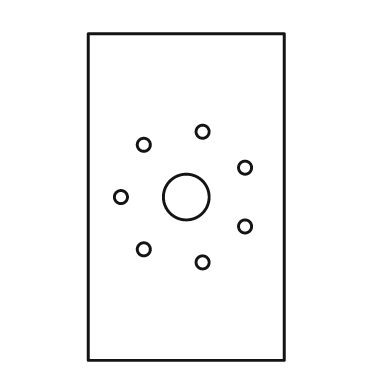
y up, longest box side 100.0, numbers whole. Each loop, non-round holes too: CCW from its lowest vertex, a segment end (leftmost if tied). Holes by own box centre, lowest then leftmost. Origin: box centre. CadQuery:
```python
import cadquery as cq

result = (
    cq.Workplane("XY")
    .moveTo(-30.0, -50.0)
    .lineTo(30.0, -50.0)
    .lineTo(30.0, 50.0)
    .lineTo(-30.0, 50.0)
    .close()
    .moveTo(5.0, -20.0)
    .circle(2.0)
    .moveTo(-13.0, -16.0)
    .circle(2.0)
    .moveTo(18.0, -9.0)
    .circle(2.0)
    .moveTo(-20.0, 0.0)
    .circle(2.0)
    .moveTo(0.0, 0.0)
    .circle(7.0)
    .moveTo(18.0, 9.0)
    .circle(2.0)
    .moveTo(-13.0, 16.0)
    .circle(2.0)
    .moveTo(5.0, 20.0)
    .circle(2.0)
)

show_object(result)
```